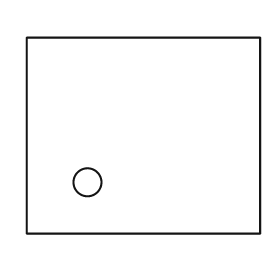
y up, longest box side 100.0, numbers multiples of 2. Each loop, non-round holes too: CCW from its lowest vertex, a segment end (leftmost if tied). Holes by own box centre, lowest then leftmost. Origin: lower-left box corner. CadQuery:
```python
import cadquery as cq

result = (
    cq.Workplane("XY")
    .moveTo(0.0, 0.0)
    .lineTo(100.0, 0.0)
    .lineTo(100.0, 84.0)
    .lineTo(0.0, 84.0)
    .close()
    .moveTo(26.0, 22.0)
    .circle(6.0)
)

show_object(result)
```